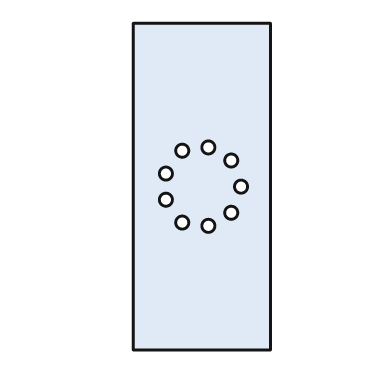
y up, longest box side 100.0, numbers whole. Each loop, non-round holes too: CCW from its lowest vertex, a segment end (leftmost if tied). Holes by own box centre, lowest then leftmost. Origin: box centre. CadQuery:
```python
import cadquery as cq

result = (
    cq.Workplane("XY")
    .moveTo(-21.0, -50.0)
    .lineTo(21.0, -50.0)
    .lineTo(21.0, 50.0)
    .lineTo(-21.0, 50.0)
    .close()
    .moveTo(2.0, -12.0)
    .circle(2.0)
    .moveTo(-6.0, -11.0)
    .circle(2.0)
    .moveTo(9.0, -8.0)
    .circle(2.0)
    .moveTo(-11.0, -4.0)
    .circle(2.0)
    .moveTo(12.0, 0.0)
    .circle(2.0)
    .moveTo(-11.0, 4.0)
    .circle(2.0)
    .moveTo(9.0, 8.0)
    .circle(2.0)
    .moveTo(-6.0, 11.0)
    .circle(2.0)
    .moveTo(2.0, 12.0)
    .circle(2.0)
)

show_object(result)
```